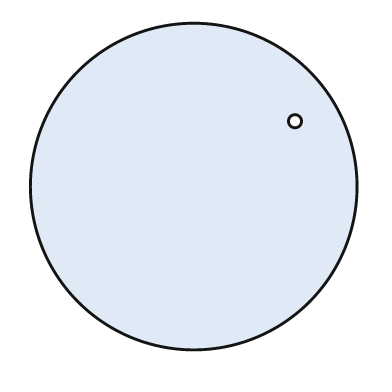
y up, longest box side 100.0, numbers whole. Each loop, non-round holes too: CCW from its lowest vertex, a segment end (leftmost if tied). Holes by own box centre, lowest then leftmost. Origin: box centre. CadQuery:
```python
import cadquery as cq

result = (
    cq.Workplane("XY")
    .moveTo(0.0, 0.0)
    .circle(50.0)
    .moveTo(31.0, 20.0)
    .circle(2.0)
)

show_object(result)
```